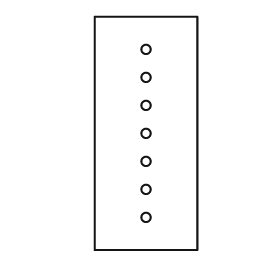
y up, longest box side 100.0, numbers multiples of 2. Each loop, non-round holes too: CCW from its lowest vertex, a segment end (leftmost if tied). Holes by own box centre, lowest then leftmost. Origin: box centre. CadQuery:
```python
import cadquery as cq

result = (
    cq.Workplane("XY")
    .moveTo(-22.0, -50.0)
    .lineTo(22.0, -50.0)
    .lineTo(22.0, 50.0)
    .lineTo(-22.0, 50.0)
    .close()
    .moveTo(0.0, -36.0)
    .circle(2.0)
    .moveTo(0.0, -24.0)
    .circle(2.0)
    .moveTo(0.0, -12.0)
    .circle(2.0)
    .moveTo(0.0, 0.0)
    .circle(2.0)
    .moveTo(0.0, 12.0)
    .circle(2.0)
    .moveTo(0.0, 24.0)
    .circle(2.0)
    .moveTo(0.0, 36.0)
    .circle(2.0)
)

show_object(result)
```